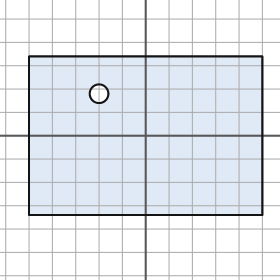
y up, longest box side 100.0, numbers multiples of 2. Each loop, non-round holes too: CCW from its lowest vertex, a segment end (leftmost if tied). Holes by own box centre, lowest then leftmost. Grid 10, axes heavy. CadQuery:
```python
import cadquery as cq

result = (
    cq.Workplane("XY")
    .moveTo(-50.0, -34.0)
    .lineTo(50.0, -34.0)
    .lineTo(50.0, 34.0)
    .lineTo(-50.0, 34.0)
    .close()
    .moveTo(-20.0, 18.0)
    .circle(4.0)
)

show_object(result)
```